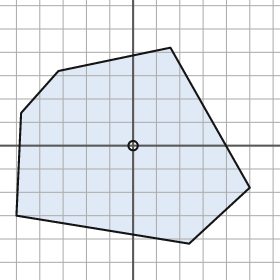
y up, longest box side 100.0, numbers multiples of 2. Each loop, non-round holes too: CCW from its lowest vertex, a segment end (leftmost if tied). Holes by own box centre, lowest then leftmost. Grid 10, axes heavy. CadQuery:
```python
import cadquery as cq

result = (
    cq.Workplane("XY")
    .moveTo(24.0, -42.0)
    .lineTo(50.0, -18.0)
    .lineTo(16.0, 42.0)
    .lineTo(-32.0, 32.0)
    .lineTo(-48.0, 14.0)
    .lineTo(-50.0, -30.0)
    .close()
    .moveTo(0.0, 0.0)
    .circle(2.0)
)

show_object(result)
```